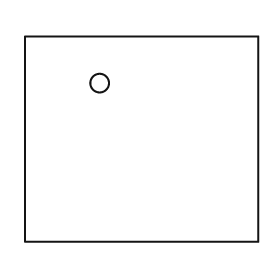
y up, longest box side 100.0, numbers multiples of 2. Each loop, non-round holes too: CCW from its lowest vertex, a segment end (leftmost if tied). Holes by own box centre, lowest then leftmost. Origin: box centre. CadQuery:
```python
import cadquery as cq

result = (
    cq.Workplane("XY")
    .moveTo(-50.0, -44.0)
    .lineTo(50.0, -44.0)
    .lineTo(50.0, 44.0)
    .lineTo(-50.0, 44.0)
    .close()
    .moveTo(-18.0, 24.0)
    .circle(4.0)
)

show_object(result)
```